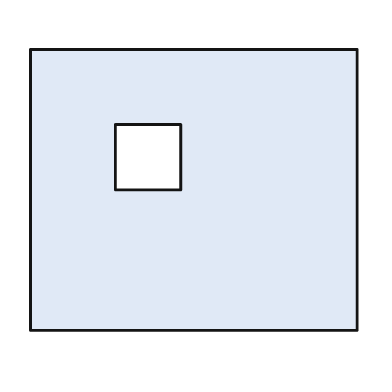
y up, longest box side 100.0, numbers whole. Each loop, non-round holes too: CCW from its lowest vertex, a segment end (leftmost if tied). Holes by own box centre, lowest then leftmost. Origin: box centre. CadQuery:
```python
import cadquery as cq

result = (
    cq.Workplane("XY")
    .moveTo(-50.0, -43.0)
    .lineTo(50.0, -43.0)
    .lineTo(50.0, 43.0)
    .lineTo(-50.0, 43.0)
    .close()
    .moveTo(-24.0, 0.0)
    .lineTo(-4.0, 0.0)
    .lineTo(-4.0, 20.0)
    .lineTo(-24.0, 20.0)
    .close()
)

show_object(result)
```